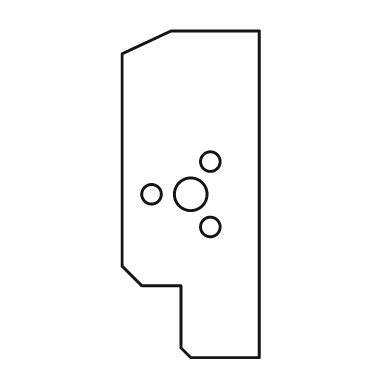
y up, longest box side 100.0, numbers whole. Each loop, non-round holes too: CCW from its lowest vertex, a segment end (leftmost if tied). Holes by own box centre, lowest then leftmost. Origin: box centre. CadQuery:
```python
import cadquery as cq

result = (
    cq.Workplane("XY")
    .moveTo(0.0, -50.0)
    .lineTo(21.0, -50.0)
    .lineTo(21.0, 50.0)
    .lineTo(-6.0, 50.0)
    .lineTo(-21.0, 43.0)
    .lineTo(-21.0, -22.0)
    .lineTo(-15.0, -28.0)
    .lineTo(-3.0, -28.0)
    .lineTo(-3.0, -47.0)
    .close()
    .moveTo(6.0, -10.0)
    .circle(3.0)
    .moveTo(-12.0, 0.0)
    .circle(3.0)
    .moveTo(0.0, 0.0)
    .circle(5.0)
    .moveTo(6.0, 10.0)
    .circle(3.0)
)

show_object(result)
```